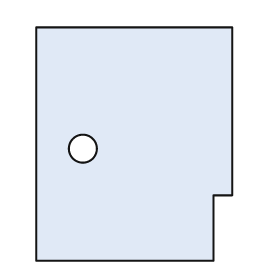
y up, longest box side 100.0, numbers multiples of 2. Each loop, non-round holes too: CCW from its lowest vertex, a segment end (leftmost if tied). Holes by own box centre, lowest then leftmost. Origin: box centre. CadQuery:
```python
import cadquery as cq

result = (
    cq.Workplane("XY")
    .moveTo(-42.0, -50.0)
    .lineTo(34.0, -50.0)
    .lineTo(34.0, -22.0)
    .lineTo(42.0, -22.0)
    .lineTo(42.0, 50.0)
    .lineTo(-42.0, 50.0)
    .close()
    .moveTo(-22.0, -2.0)
    .circle(6.0)
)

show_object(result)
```